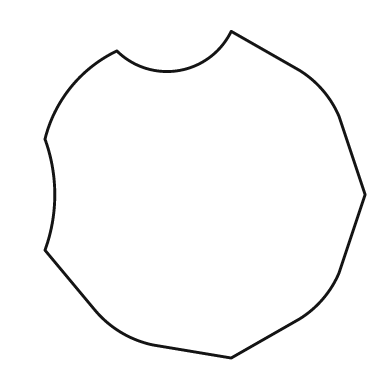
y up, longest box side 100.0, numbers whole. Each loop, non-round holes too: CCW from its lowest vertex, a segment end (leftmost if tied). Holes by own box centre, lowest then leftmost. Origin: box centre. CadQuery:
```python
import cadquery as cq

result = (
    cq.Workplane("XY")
    .moveTo(8.0, -50.0)
    .lineTo(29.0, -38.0)
    .threePointArc((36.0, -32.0), (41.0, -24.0))
    .lineTo(49.0, 0.0)
    .lineTo(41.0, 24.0)
    .threePointArc((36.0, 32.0), (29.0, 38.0))
    .lineTo(8.0, 50.0)
    .threePointArc((-8.0, 38.0), (-27.0, 44.0))
    .threePointArc((-41.0, 33.0), (-49.0, 17.0))
    .threePointArc((-46.0, 0.0), (-49.0, -17.0))
    .lineTo(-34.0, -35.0)
    .threePointArc((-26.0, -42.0), (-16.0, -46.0))
    .close()
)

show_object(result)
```